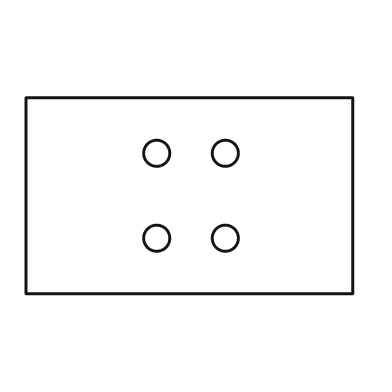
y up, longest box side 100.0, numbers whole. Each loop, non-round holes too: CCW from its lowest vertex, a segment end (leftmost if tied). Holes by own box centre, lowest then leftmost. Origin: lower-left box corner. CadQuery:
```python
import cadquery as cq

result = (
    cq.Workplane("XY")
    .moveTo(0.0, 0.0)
    .lineTo(100.0, 0.0)
    .lineTo(100.0, 60.0)
    .lineTo(0.0, 60.0)
    .close()
    .moveTo(40.0, 17.0)
    .circle(4.0)
    .moveTo(61.0, 17.0)
    .circle(4.0)
    .moveTo(40.0, 43.0)
    .circle(4.0)
    .moveTo(61.0, 43.0)
    .circle(4.0)
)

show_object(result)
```